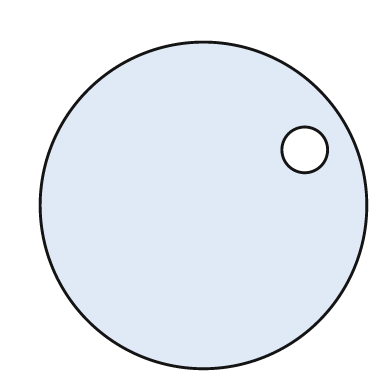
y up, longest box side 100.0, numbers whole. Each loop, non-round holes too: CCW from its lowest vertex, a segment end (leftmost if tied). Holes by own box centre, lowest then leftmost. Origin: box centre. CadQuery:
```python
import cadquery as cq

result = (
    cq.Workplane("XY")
    .moveTo(0.0, 0.0)
    .circle(50.0)
    .moveTo(31.0, 17.0)
    .circle(7.0)
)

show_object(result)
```